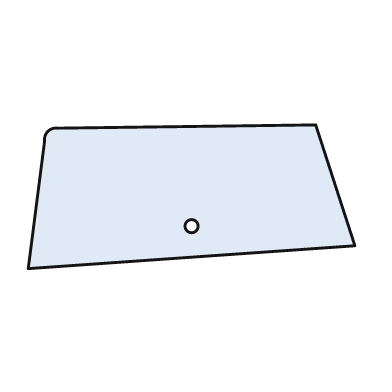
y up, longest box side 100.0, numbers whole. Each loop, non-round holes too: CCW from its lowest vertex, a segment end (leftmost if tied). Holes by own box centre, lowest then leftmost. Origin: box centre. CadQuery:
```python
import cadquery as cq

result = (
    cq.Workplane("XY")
    .moveTo(-50.0, -22.0)
    .lineTo(50.0, -15.0)
    .lineTo(38.0, 22.0)
    .lineTo(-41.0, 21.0)
    .threePointArc((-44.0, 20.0), (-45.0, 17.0))
    .close()
    .moveTo(0.0, -9.0)
    .circle(2.0)
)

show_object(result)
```